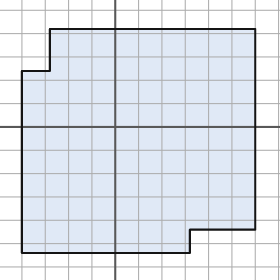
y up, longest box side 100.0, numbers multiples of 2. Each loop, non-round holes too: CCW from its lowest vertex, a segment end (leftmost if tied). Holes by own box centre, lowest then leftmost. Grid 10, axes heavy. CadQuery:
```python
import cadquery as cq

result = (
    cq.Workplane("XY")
    .moveTo(-40.0, -54.0)
    .lineTo(32.0, -54.0)
    .lineTo(32.0, -44.0)
    .lineTo(60.0, -44.0)
    .lineTo(60.0, 42.0)
    .lineTo(-28.0, 42.0)
    .lineTo(-28.0, 24.0)
    .lineTo(-40.0, 24.0)
    .close()
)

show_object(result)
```